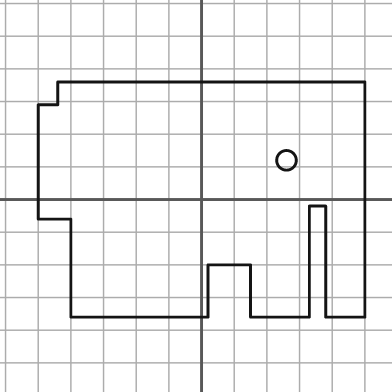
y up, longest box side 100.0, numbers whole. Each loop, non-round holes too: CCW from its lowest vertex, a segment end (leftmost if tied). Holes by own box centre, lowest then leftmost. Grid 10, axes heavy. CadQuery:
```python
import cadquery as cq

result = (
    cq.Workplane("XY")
    .moveTo(-40.0, -36.0)
    .lineTo(2.0, -36.0)
    .lineTo(2.0, -20.0)
    .lineTo(15.0, -20.0)
    .lineTo(15.0, -36.0)
    .lineTo(33.0, -36.0)
    .lineTo(33.0, -2.0)
    .lineTo(38.0, -2.0)
    .lineTo(38.0, -36.0)
    .lineTo(50.0, -36.0)
    .lineTo(50.0, 36.0)
    .lineTo(-44.0, 36.0)
    .lineTo(-44.0, 29.0)
    .lineTo(-50.0, 29.0)
    .lineTo(-50.0, -6.0)
    .lineTo(-40.0, -6.0)
    .close()
    .moveTo(26.0, 12.0)
    .circle(3.0)
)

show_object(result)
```